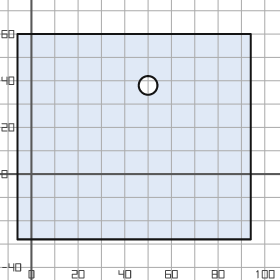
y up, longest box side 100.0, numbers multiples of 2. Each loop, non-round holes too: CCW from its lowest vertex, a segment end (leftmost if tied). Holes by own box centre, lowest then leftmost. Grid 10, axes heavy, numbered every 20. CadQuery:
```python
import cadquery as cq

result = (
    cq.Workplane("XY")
    .moveTo(-6.0, -28.0)
    .lineTo(94.0, -28.0)
    .lineTo(94.0, 60.0)
    .lineTo(-6.0, 60.0)
    .close()
    .moveTo(50.0, 38.0)
    .circle(4.0)
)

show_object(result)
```